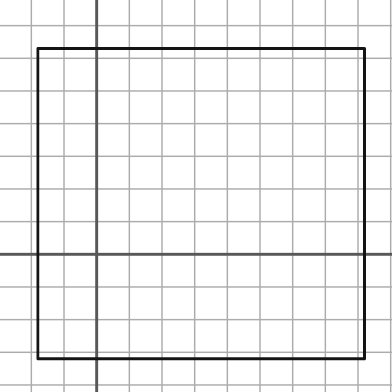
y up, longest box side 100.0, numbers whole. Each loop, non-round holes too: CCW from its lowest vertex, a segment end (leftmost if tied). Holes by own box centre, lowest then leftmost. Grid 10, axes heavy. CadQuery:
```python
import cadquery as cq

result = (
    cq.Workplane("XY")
    .moveTo(-18.0, -32.0)
    .lineTo(82.0, -32.0)
    .lineTo(82.0, 63.0)
    .lineTo(-18.0, 63.0)
    .close()
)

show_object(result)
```